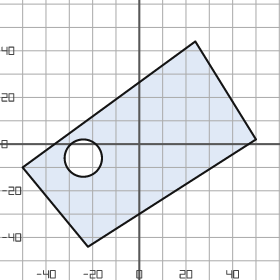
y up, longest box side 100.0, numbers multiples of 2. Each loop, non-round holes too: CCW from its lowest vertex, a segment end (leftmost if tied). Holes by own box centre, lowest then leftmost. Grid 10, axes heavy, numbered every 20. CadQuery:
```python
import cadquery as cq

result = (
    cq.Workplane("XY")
    .moveTo(-22.0, -44.0)
    .lineTo(50.0, 2.0)
    .lineTo(24.0, 44.0)
    .lineTo(-50.0, -10.0)
    .close()
    .moveTo(-24.0, -6.0)
    .circle(8.0)
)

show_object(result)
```